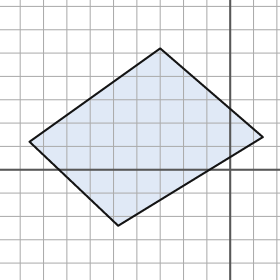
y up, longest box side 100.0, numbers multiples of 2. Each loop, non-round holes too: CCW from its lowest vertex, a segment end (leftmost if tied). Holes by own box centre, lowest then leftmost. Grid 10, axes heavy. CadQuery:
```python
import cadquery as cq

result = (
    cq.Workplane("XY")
    .moveTo(-48.0, -24.0)
    .lineTo(14.0, 14.0)
    .lineTo(-30.0, 52.0)
    .lineTo(-86.0, 12.0)
    .close()
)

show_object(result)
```